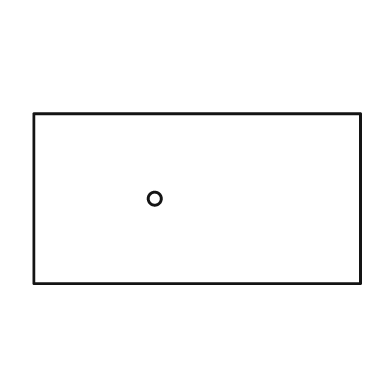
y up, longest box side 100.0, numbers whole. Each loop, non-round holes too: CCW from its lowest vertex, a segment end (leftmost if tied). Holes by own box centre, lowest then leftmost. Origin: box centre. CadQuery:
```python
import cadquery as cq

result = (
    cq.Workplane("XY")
    .moveTo(-50.0, -26.0)
    .lineTo(50.0, -26.0)
    .lineTo(50.0, 26.0)
    .lineTo(-50.0, 26.0)
    .close()
    .moveTo(-13.0, 0.0)
    .circle(2.0)
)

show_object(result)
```